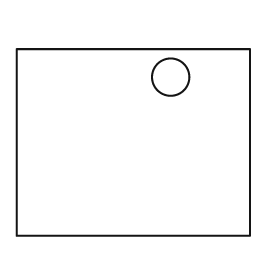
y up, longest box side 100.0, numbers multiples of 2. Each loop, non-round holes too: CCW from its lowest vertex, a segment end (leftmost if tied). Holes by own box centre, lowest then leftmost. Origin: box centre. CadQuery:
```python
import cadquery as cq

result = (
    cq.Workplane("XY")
    .moveTo(-50.0, -40.0)
    .lineTo(50.0, -40.0)
    .lineTo(50.0, 40.0)
    .lineTo(-50.0, 40.0)
    .close()
    .moveTo(16.0, 28.0)
    .circle(8.0)
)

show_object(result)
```